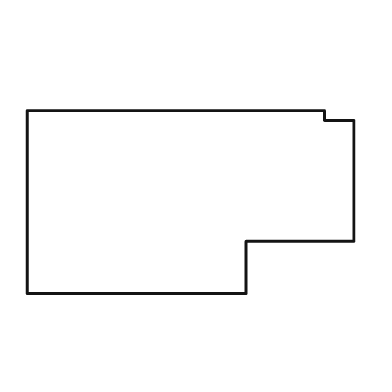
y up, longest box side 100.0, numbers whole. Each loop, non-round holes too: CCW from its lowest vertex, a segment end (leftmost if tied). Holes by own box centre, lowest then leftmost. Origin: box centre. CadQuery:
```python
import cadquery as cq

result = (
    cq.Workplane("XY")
    .moveTo(-50.0, -28.0)
    .lineTo(17.0, -28.0)
    .lineTo(17.0, -12.0)
    .lineTo(50.0, -12.0)
    .lineTo(50.0, 25.0)
    .lineTo(41.0, 25.0)
    .lineTo(41.0, 28.0)
    .lineTo(-50.0, 28.0)
    .close()
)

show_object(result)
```